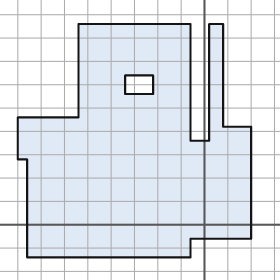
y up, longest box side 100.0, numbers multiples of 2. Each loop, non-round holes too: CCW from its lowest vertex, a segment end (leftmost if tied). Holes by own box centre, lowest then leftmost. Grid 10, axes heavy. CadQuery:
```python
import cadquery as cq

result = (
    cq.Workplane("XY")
    .moveTo(-76.0, -14.0)
    .lineTo(-6.0, -14.0)
    .lineTo(-6.0, -6.0)
    .lineTo(20.0, -6.0)
    .lineTo(20.0, 42.0)
    .lineTo(8.0, 42.0)
    .lineTo(8.0, 86.0)
    .lineTo(2.0, 86.0)
    .lineTo(2.0, 36.0)
    .lineTo(-6.0, 36.0)
    .lineTo(-6.0, 86.0)
    .lineTo(-54.0, 86.0)
    .lineTo(-54.0, 46.0)
    .lineTo(-80.0, 46.0)
    .lineTo(-80.0, 28.0)
    .lineTo(-76.0, 28.0)
    .close()
    .moveTo(-34.0, 56.0)
    .lineTo(-22.0, 56.0)
    .lineTo(-22.0, 64.0)
    .lineTo(-34.0, 64.0)
    .close()
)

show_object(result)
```